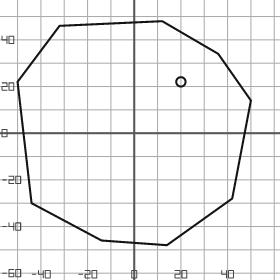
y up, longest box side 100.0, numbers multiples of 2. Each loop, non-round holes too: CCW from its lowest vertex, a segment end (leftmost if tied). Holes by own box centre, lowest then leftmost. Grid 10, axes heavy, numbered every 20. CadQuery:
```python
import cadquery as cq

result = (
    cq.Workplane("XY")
    .moveTo(14.0, -48.0)
    .lineTo(42.0, -28.0)
    .lineTo(50.0, 14.0)
    .lineTo(36.0, 34.0)
    .lineTo(12.0, 48.0)
    .lineTo(-32.0, 46.0)
    .lineTo(-50.0, 22.0)
    .lineTo(-44.0, -30.0)
    .lineTo(-14.0, -46.0)
    .close()
    .moveTo(20.0, 22.0)
    .circle(2.0)
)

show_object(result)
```